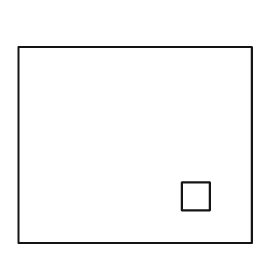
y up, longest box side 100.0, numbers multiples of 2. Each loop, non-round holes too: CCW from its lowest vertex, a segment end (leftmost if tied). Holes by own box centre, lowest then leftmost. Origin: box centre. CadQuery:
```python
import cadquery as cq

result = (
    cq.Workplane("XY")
    .moveTo(-50.0, -42.0)
    .lineTo(50.0, -42.0)
    .lineTo(50.0, 42.0)
    .lineTo(-50.0, 42.0)
    .close()
    .moveTo(20.0, -28.0)
    .lineTo(32.0, -28.0)
    .lineTo(32.0, -16.0)
    .lineTo(20.0, -16.0)
    .close()
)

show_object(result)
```